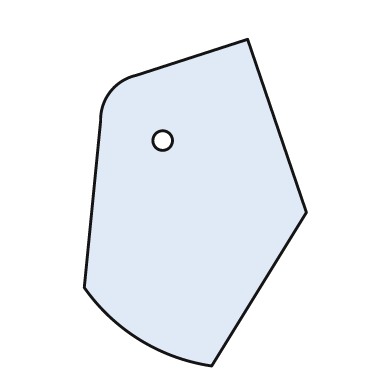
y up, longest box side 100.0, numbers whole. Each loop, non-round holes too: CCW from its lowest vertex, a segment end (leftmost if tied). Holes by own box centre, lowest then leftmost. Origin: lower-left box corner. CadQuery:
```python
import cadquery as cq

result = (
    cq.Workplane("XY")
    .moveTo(39.0, 0.0)
    .lineTo(68.0, 47.0)
    .lineTo(50.0, 100.0)
    .lineTo(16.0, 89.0)
    .threePointArc((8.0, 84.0), (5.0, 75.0))
    .lineTo(0.0, 24.0)
    .threePointArc((17.0, 8.0), (39.0, 0.0))
    .close()
    .moveTo(24.0, 69.0)
    .circle(3.0)
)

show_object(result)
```